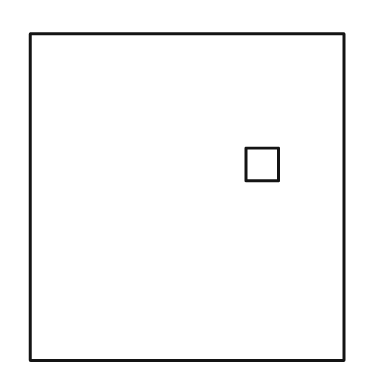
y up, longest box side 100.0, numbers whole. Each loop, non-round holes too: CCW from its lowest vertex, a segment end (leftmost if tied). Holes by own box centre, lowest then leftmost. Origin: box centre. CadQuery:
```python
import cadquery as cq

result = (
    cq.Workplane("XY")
    .moveTo(-48.0, -50.0)
    .lineTo(48.0, -50.0)
    .lineTo(48.0, 50.0)
    .lineTo(-48.0, 50.0)
    .close()
    .moveTo(18.0, 5.0)
    .lineTo(28.0, 5.0)
    .lineTo(28.0, 15.0)
    .lineTo(18.0, 15.0)
    .close()
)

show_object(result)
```